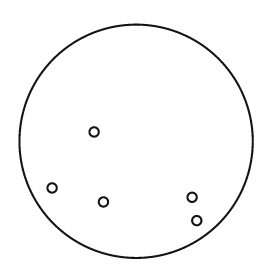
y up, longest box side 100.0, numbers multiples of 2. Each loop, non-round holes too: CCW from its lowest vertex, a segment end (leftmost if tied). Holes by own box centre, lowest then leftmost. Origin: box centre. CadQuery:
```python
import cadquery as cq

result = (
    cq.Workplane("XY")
    .moveTo(0.0, 0.0)
    .circle(50.0)
    .moveTo(26.0, -34.0)
    .circle(2.0)
    .moveTo(-14.0, -26.0)
    .circle(2.0)
    .moveTo(24.0, -24.0)
    .circle(2.0)
    .moveTo(-36.0, -20.0)
    .circle(2.0)
    .moveTo(-18.0, 4.0)
    .circle(2.0)
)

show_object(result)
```